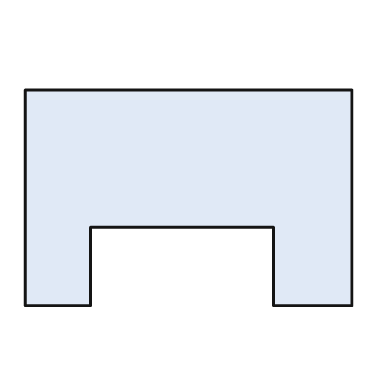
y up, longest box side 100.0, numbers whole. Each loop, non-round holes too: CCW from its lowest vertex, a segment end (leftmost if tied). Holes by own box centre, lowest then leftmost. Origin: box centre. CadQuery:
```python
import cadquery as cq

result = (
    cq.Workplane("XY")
    .moveTo(-50.0, -33.0)
    .lineTo(-30.0, -33.0)
    .lineTo(-30.0, -9.0)
    .lineTo(26.0, -9.0)
    .lineTo(26.0, -33.0)
    .lineTo(50.0, -33.0)
    .lineTo(50.0, 33.0)
    .lineTo(-50.0, 33.0)
    .close()
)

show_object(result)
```